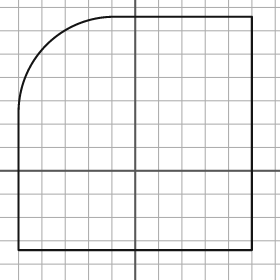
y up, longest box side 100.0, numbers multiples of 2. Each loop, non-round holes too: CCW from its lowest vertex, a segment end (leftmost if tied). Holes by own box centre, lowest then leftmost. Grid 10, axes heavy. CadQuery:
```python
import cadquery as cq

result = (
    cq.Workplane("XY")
    .moveTo(-50.0, -34.0)
    .lineTo(50.0, -34.0)
    .lineTo(50.0, 66.0)
    .lineTo(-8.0, 66.0)
    .threePointArc((-38.0, 54.0), (-50.0, 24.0))
    .close()
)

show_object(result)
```